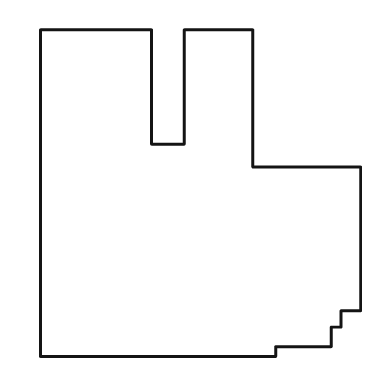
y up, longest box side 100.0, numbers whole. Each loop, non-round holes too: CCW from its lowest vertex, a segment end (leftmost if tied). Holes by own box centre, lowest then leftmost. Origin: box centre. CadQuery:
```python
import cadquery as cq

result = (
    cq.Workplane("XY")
    .moveTo(-49.0, -50.0)
    .lineTo(23.0, -50.0)
    .lineTo(23.0, -47.0)
    .lineTo(40.0, -47.0)
    .lineTo(40.0, -41.0)
    .lineTo(43.0, -41.0)
    .lineTo(43.0, -36.0)
    .lineTo(49.0, -36.0)
    .lineTo(49.0, 8.0)
    .lineTo(16.0, 8.0)
    .lineTo(16.0, 50.0)
    .lineTo(-5.0, 50.0)
    .lineTo(-5.0, 15.0)
    .lineTo(-15.0, 15.0)
    .lineTo(-15.0, 50.0)
    .lineTo(-49.0, 50.0)
    .close()
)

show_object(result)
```